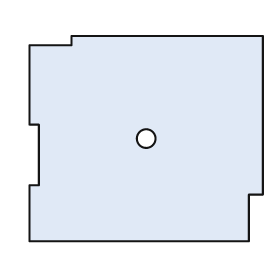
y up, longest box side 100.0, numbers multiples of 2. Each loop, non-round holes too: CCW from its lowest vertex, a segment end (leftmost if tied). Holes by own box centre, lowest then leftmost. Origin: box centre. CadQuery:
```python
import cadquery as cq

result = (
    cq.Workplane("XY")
    .moveTo(-50.0, -44.0)
    .lineTo(44.0, -44.0)
    .lineTo(44.0, -24.0)
    .lineTo(50.0, -24.0)
    .lineTo(50.0, 44.0)
    .lineTo(-32.0, 44.0)
    .lineTo(-32.0, 40.0)
    .lineTo(-50.0, 40.0)
    .lineTo(-50.0, 6.0)
    .lineTo(-46.0, 6.0)
    .lineTo(-46.0, -20.0)
    .lineTo(-50.0, -20.0)
    .close()
    .moveTo(0.0, 0.0)
    .circle(4.0)
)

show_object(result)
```